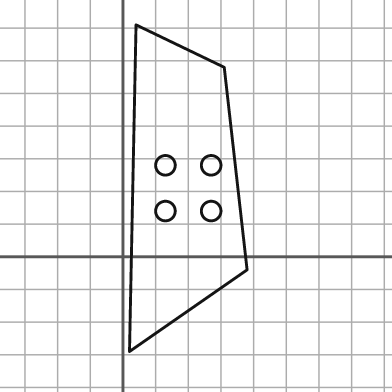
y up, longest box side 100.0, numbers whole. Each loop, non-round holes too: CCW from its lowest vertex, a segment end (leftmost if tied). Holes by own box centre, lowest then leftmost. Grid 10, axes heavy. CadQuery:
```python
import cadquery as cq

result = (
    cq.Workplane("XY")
    .moveTo(2.0, -29.0)
    .lineTo(38.0, -4.0)
    .lineTo(31.0, 58.0)
    .lineTo(4.0, 71.0)
    .close()
    .moveTo(13.0, 14.0)
    .circle(3.0)
    .moveTo(27.0, 14.0)
    .circle(3.0)
    .moveTo(13.0, 28.0)
    .circle(3.0)
    .moveTo(27.0, 28.0)
    .circle(3.0)
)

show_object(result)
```